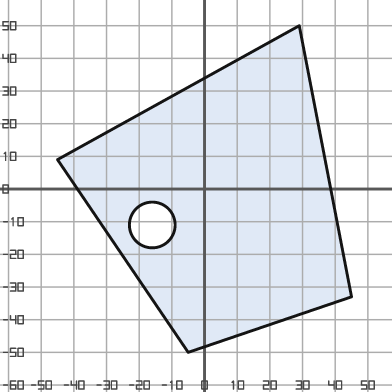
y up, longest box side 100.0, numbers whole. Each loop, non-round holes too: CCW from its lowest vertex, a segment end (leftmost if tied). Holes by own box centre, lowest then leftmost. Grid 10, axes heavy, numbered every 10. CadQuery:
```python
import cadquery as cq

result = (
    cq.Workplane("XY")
    .moveTo(-5.0, -50.0)
    .lineTo(45.0, -33.0)
    .lineTo(29.0, 50.0)
    .lineTo(-45.0, 9.0)
    .close()
    .moveTo(-16.0, -11.0)
    .circle(7.0)
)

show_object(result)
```